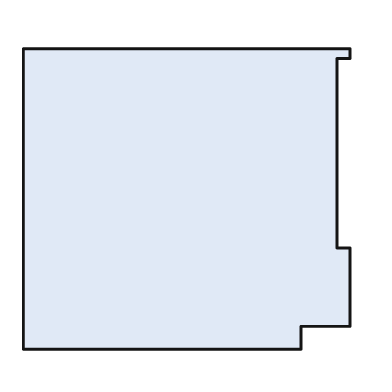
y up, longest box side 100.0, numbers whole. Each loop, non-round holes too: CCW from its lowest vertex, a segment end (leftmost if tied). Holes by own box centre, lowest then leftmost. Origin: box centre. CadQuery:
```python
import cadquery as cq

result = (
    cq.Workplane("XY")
    .moveTo(-50.0, -46.0)
    .lineTo(35.0, -46.0)
    .lineTo(35.0, -39.0)
    .lineTo(50.0, -39.0)
    .lineTo(50.0, -15.0)
    .lineTo(46.0, -15.0)
    .lineTo(46.0, 43.0)
    .lineTo(50.0, 43.0)
    .lineTo(50.0, 46.0)
    .lineTo(-50.0, 46.0)
    .close()
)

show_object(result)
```